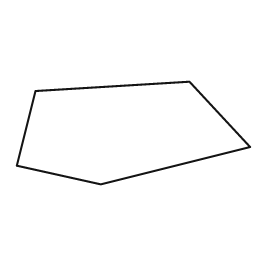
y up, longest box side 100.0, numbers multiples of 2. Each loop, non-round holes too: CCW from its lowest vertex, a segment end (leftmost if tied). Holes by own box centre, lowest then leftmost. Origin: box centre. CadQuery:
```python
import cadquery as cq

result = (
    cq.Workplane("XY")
    .moveTo(-14.0, -22.0)
    .lineTo(50.0, -6.0)
    .lineTo(24.0, 22.0)
    .lineTo(-42.0, 18.0)
    .lineTo(-50.0, -14.0)
    .close()
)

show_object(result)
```